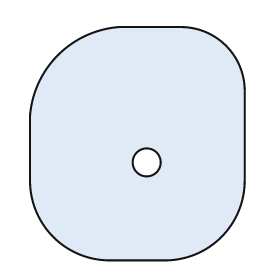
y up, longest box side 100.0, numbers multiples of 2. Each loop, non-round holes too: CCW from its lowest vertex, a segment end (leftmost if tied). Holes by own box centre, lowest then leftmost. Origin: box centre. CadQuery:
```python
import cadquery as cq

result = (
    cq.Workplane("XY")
    .moveTo(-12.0, -50.0)
    .lineTo(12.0, -50.0)
    .threePointArc((36.0, -40.0), (46.0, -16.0))
    .lineTo(46.0, 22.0)
    .threePointArc((38.0, 42.0), (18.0, 50.0))
    .lineTo(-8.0, 50.0)
    .threePointArc((-34.0, 38.0), (-46.0, 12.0))
    .lineTo(-46.0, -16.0)
    .threePointArc((-36.0, -40.0), (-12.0, -50.0))
    .close()
    .moveTo(4.0, -8.0)
    .circle(6.0)
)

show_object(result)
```